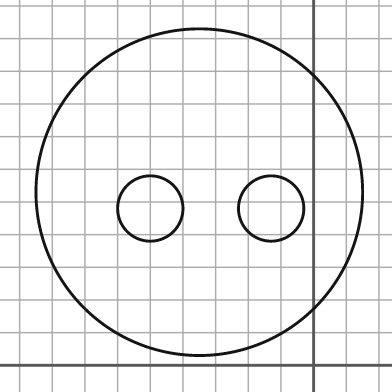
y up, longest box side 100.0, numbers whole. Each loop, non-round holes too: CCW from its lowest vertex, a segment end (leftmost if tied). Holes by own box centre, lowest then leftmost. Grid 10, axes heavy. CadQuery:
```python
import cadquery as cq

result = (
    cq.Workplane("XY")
    .moveTo(-35.0, 53.0)
    .circle(50.0)
    .moveTo(-50.0, 48.0)
    .circle(10.0)
    .moveTo(-13.0, 48.0)
    .circle(10.0)
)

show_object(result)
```